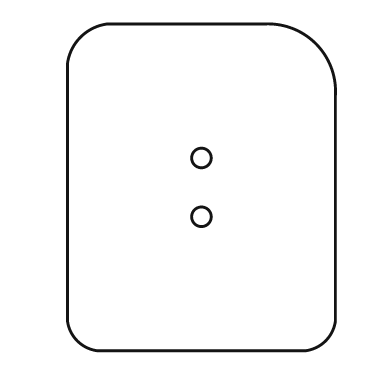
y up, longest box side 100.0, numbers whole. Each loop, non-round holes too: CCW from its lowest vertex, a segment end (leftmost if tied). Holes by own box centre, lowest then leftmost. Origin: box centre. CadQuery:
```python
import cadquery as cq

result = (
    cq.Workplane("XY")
    .moveTo(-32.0, -50.0)
    .lineTo(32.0, -50.0)
    .threePointArc((38.0, -47.0), (41.0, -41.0))
    .lineTo(41.0, 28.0)
    .threePointArc((35.0, 44.0), (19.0, 50.0))
    .lineTo(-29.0, 50.0)
    .threePointArc((-37.0, 46.0), (-41.0, 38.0))
    .lineTo(-41.0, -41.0)
    .threePointArc((-38.0, -47.0), (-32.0, -50.0))
    .close()
    .moveTo(0.0, -9.0)
    .circle(3.0)
    .moveTo(0.0, 9.0)
    .circle(3.0)
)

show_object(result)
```